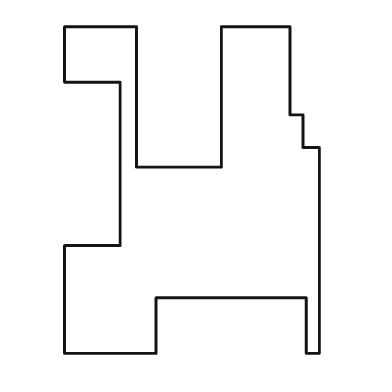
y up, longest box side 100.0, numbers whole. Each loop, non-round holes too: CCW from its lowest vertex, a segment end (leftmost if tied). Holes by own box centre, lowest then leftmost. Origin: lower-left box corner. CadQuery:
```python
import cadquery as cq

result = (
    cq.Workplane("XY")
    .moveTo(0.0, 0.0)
    .lineTo(28.0, 0.0)
    .lineTo(28.0, 17.0)
    .lineTo(74.0, 17.0)
    .lineTo(74.0, 0.0)
    .lineTo(78.0, 0.0)
    .lineTo(78.0, 63.0)
    .lineTo(73.0, 63.0)
    .lineTo(73.0, 73.0)
    .lineTo(69.0, 73.0)
    .lineTo(69.0, 100.0)
    .lineTo(48.0, 100.0)
    .lineTo(48.0, 57.0)
    .lineTo(22.0, 57.0)
    .lineTo(22.0, 100.0)
    .lineTo(0.0, 100.0)
    .lineTo(0.0, 83.0)
    .lineTo(17.0, 83.0)
    .lineTo(17.0, 33.0)
    .lineTo(0.0, 33.0)
    .close()
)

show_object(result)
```